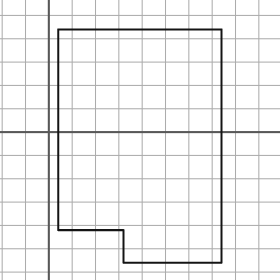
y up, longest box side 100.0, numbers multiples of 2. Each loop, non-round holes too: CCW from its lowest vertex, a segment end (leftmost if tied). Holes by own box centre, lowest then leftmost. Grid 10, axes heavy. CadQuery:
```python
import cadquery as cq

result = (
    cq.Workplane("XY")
    .moveTo(32.0, -56.0)
    .lineTo(74.0, -56.0)
    .lineTo(74.0, 44.0)
    .lineTo(4.0, 44.0)
    .lineTo(4.0, -42.0)
    .lineTo(32.0, -42.0)
    .close()
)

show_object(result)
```